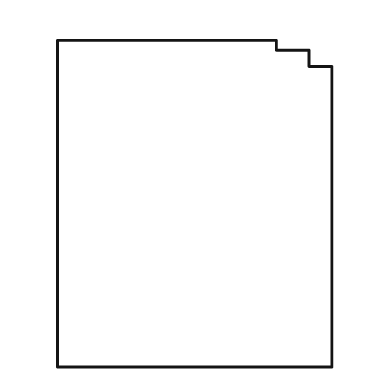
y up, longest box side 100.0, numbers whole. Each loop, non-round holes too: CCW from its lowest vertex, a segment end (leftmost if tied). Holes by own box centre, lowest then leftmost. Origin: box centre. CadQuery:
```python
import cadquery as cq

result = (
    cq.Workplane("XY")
    .moveTo(-42.0, -50.0)
    .lineTo(42.0, -50.0)
    .lineTo(42.0, 42.0)
    .lineTo(35.0, 42.0)
    .lineTo(35.0, 47.0)
    .lineTo(25.0, 47.0)
    .lineTo(25.0, 50.0)
    .lineTo(-42.0, 50.0)
    .close()
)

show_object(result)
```